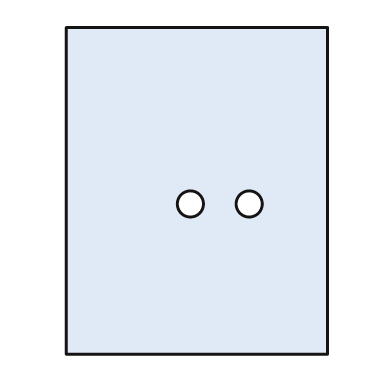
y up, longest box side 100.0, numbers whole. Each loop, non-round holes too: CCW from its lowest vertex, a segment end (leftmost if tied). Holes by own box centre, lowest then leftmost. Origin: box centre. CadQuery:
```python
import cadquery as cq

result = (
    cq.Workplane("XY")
    .moveTo(-40.0, -50.0)
    .lineTo(40.0, -50.0)
    .lineTo(40.0, 50.0)
    .lineTo(-40.0, 50.0)
    .close()
    .moveTo(-2.0, -4.0)
    .circle(4.0)
    .moveTo(16.0, -4.0)
    .circle(4.0)
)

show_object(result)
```